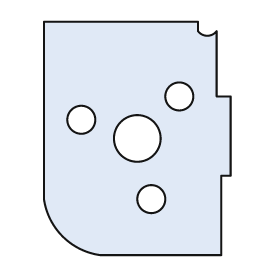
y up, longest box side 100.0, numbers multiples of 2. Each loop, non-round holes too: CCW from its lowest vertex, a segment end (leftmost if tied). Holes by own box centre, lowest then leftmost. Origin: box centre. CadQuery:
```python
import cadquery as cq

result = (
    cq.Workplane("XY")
    .moveTo(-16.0, -50.0)
    .lineTo(36.0, -50.0)
    .lineTo(36.0, -16.0)
    .lineTo(40.0, -16.0)
    .lineTo(40.0, 18.0)
    .lineTo(34.0, 18.0)
    .lineTo(34.0, 46.0)
    .threePointArc((30.0, 44.0), (26.0, 46.0))
    .lineTo(26.0, 50.0)
    .lineTo(-40.0, 50.0)
    .lineTo(-40.0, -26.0)
    .threePointArc((-32.0, -42.0), (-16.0, -50.0))
    .close()
    .moveTo(6.0, -26.0)
    .circle(6.0)
    .moveTo(0.0, 0.0)
    .circle(10.0)
    .moveTo(-24.0, 8.0)
    .circle(6.0)
    .moveTo(18.0, 18.0)
    .circle(6.0)
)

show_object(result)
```